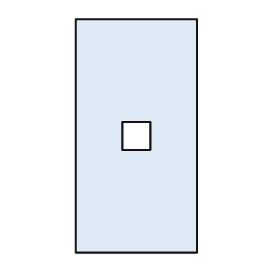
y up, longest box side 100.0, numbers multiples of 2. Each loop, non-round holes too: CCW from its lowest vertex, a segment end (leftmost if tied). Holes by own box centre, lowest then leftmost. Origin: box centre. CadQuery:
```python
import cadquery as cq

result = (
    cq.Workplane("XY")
    .moveTo(-26.0, -50.0)
    .lineTo(26.0, -50.0)
    .lineTo(26.0, 50.0)
    .lineTo(-26.0, 50.0)
    .close()
    .moveTo(-6.0, -6.0)
    .lineTo(6.0, -6.0)
    .lineTo(6.0, 6.0)
    .lineTo(-6.0, 6.0)
    .close()
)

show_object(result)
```